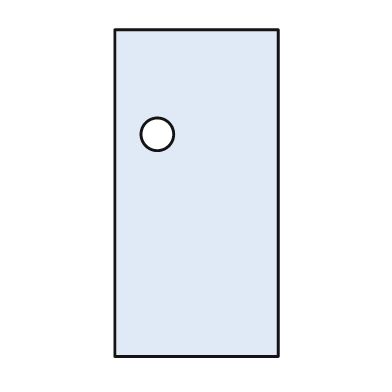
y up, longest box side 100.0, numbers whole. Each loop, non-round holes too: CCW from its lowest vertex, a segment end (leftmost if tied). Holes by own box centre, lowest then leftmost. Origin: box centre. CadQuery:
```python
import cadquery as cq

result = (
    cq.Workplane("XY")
    .moveTo(-25.0, -50.0)
    .lineTo(25.0, -50.0)
    .lineTo(25.0, 50.0)
    .lineTo(-25.0, 50.0)
    .close()
    .moveTo(-12.0, 18.0)
    .circle(5.0)
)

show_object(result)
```